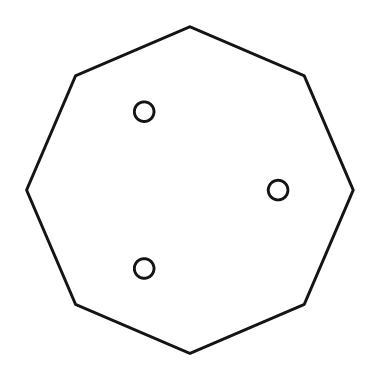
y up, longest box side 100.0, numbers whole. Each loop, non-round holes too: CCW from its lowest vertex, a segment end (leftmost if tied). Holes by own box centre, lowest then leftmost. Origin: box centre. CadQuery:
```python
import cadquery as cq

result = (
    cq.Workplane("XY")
    .moveTo(0.0, -50.0)
    .lineTo(35.0, -35.0)
    .lineTo(50.0, 0.0)
    .lineTo(35.0, 35.0)
    .lineTo(0.0, 50.0)
    .lineTo(-35.0, 35.0)
    .lineTo(-50.0, 0.0)
    .lineTo(-35.0, -35.0)
    .close()
    .moveTo(-14.0, -24.0)
    .circle(3.0)
    .moveTo(27.0, 0.0)
    .circle(3.0)
    .moveTo(-14.0, 24.0)
    .circle(3.0)
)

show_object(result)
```